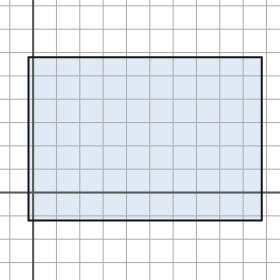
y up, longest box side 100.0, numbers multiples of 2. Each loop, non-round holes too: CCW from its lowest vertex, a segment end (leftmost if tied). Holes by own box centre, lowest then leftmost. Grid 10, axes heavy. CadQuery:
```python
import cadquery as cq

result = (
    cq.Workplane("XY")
    .moveTo(-2.0, -12.0)
    .lineTo(98.0, -12.0)
    .lineTo(98.0, 58.0)
    .lineTo(-2.0, 58.0)
    .close()
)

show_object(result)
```